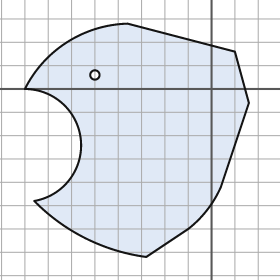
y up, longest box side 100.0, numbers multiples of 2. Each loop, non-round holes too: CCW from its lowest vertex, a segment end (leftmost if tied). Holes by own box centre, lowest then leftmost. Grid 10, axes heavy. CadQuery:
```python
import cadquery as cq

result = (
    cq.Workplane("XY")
    .moveTo(-28.0, -72.0)
    .lineTo(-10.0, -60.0)
    .threePointArc((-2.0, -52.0), (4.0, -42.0))
    .lineTo(16.0, -6.0)
    .lineTo(10.0, 16.0)
    .lineTo(-36.0, 28.0)
    .threePointArc((-62.0, 20.0), (-80.0, 0.0))
    .threePointArc((-56.0, -22.0), (-76.0, -48.0))
    .threePointArc((-54.0, -64.0), (-28.0, -72.0))
    .close()
    .moveTo(-50.0, 6.0)
    .circle(2.0)
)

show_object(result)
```